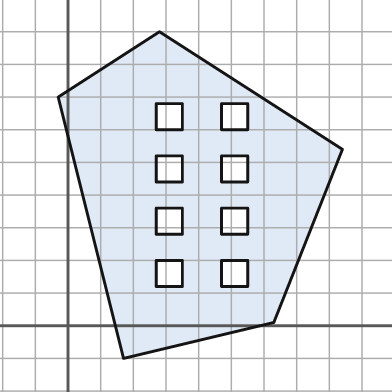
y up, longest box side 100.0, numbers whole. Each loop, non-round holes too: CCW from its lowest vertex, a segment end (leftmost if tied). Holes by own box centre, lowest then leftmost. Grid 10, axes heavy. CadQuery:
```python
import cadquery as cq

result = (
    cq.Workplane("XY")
    .moveTo(17.0, -10.0)
    .lineTo(63.0, 1.0)
    .lineTo(84.0, 54.0)
    .lineTo(28.0, 90.0)
    .lineTo(-3.0, 70.0)
    .close()
    .moveTo(27.0, 12.0)
    .lineTo(35.0, 12.0)
    .lineTo(35.0, 20.0)
    .lineTo(27.0, 20.0)
    .close()
    .moveTo(47.0, 12.0)
    .lineTo(55.0, 12.0)
    .lineTo(55.0, 20.0)
    .lineTo(47.0, 20.0)
    .close()
    .moveTo(27.0, 28.0)
    .lineTo(35.0, 28.0)
    .lineTo(35.0, 36.0)
    .lineTo(27.0, 36.0)
    .close()
    .moveTo(47.0, 28.0)
    .lineTo(55.0, 28.0)
    .lineTo(55.0, 36.0)
    .lineTo(47.0, 36.0)
    .close()
    .moveTo(27.0, 44.0)
    .lineTo(35.0, 44.0)
    .lineTo(35.0, 52.0)
    .lineTo(27.0, 52.0)
    .close()
    .moveTo(47.0, 44.0)
    .lineTo(55.0, 44.0)
    .lineTo(55.0, 52.0)
    .lineTo(47.0, 52.0)
    .close()
    .moveTo(27.0, 60.0)
    .lineTo(35.0, 60.0)
    .lineTo(35.0, 68.0)
    .lineTo(27.0, 68.0)
    .close()
    .moveTo(47.0, 60.0)
    .lineTo(55.0, 60.0)
    .lineTo(55.0, 68.0)
    .lineTo(47.0, 68.0)
    .close()
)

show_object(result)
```